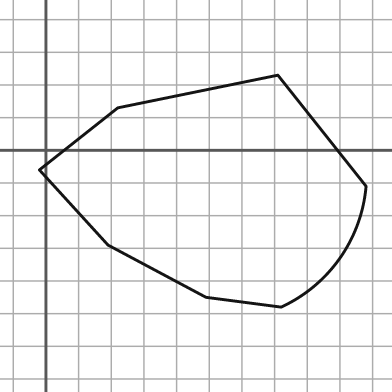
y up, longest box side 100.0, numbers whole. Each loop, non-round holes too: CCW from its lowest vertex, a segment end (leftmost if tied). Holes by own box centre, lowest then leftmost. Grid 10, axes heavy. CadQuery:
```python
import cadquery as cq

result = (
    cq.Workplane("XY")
    .moveTo(72.0, -48.0)
    .threePointArc((90.0, -33.0), (98.0, -11.0))
    .lineTo(71.0, 23.0)
    .lineTo(22.0, 13.0)
    .lineTo(-2.0, -6.0)
    .lineTo(19.0, -29.0)
    .lineTo(49.0, -45.0)
    .close()
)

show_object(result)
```